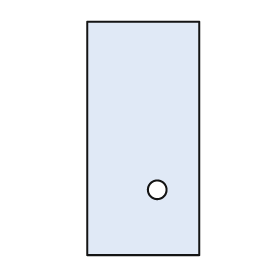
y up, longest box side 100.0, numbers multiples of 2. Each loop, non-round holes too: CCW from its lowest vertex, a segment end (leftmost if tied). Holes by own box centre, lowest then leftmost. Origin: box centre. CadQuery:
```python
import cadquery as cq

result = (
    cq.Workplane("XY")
    .moveTo(-24.0, -50.0)
    .lineTo(24.0, -50.0)
    .lineTo(24.0, 50.0)
    .lineTo(-24.0, 50.0)
    .close()
    .moveTo(6.0, -22.0)
    .circle(4.0)
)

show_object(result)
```